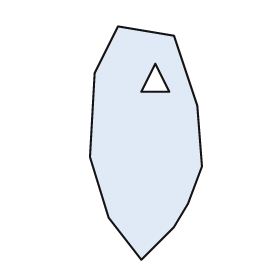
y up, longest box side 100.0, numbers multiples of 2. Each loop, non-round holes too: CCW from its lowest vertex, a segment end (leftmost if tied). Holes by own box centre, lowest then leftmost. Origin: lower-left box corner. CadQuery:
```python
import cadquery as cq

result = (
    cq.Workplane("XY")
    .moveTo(22.0, 0.0)
    .lineTo(36.0, 14.0)
    .lineTo(42.0, 24.0)
    .lineTo(48.0, 40.0)
    .lineTo(46.0, 66.0)
    .lineTo(36.0, 96.0)
    .lineTo(12.0, 100.0)
    .lineTo(2.0, 80.0)
    .lineTo(0.0, 44.0)
    .lineTo(8.0, 18.0)
    .close()
    .moveTo(22.0, 72.0)
    .lineTo(34.0, 72.0)
    .lineTo(28.0, 84.0)
    .close()
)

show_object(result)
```